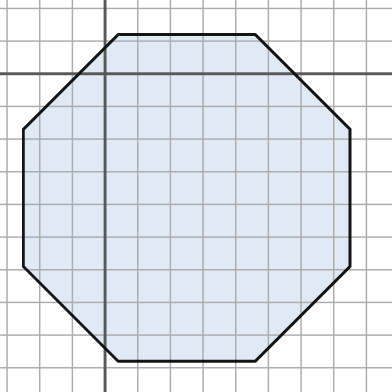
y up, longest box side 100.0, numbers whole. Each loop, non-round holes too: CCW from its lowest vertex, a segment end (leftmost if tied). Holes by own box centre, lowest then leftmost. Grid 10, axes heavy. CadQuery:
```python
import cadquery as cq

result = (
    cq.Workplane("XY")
    .moveTo(4.0, -88.0)
    .lineTo(46.0, -88.0)
    .lineTo(75.0, -59.0)
    .lineTo(75.0, -17.0)
    .lineTo(46.0, 12.0)
    .lineTo(4.0, 12.0)
    .lineTo(-25.0, -17.0)
    .lineTo(-25.0, -59.0)
    .close()
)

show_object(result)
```